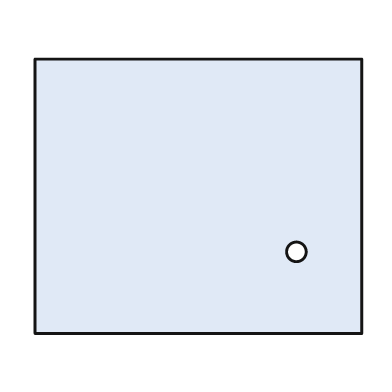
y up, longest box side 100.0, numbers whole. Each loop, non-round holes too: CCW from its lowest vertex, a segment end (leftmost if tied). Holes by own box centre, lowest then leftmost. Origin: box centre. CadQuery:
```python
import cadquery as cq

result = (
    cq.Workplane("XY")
    .moveTo(-50.0, -42.0)
    .lineTo(50.0, -42.0)
    .lineTo(50.0, 42.0)
    .lineTo(-50.0, 42.0)
    .close()
    .moveTo(30.0, -17.0)
    .circle(3.0)
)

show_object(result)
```